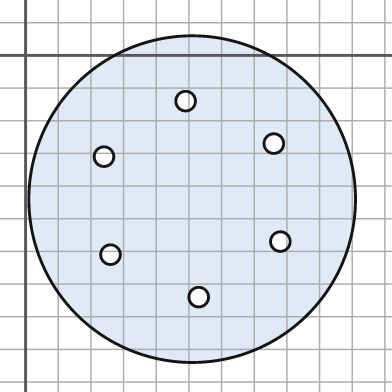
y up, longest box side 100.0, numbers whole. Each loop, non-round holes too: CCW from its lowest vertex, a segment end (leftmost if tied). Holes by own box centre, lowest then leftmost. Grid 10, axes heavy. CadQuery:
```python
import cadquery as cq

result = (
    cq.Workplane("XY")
    .moveTo(51.0, -44.0)
    .circle(50.0)
    .moveTo(53.0, -74.0)
    .circle(3.0)
    .moveTo(26.0, -61.0)
    .circle(3.0)
    .moveTo(78.0, -57.0)
    .circle(3.0)
    .moveTo(24.0, -31.0)
    .circle(3.0)
    .moveTo(76.0, -27.0)
    .circle(3.0)
    .moveTo(49.0, -14.0)
    .circle(3.0)
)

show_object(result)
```